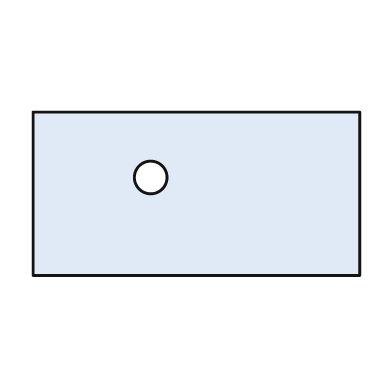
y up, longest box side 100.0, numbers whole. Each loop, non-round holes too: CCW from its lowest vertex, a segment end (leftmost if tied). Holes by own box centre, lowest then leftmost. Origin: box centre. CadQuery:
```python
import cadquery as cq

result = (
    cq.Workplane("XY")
    .moveTo(-50.0, -25.0)
    .lineTo(50.0, -25.0)
    .lineTo(50.0, 25.0)
    .lineTo(-50.0, 25.0)
    .close()
    .moveTo(-14.0, 5.0)
    .circle(5.0)
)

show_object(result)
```